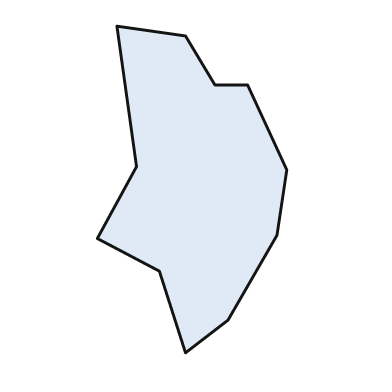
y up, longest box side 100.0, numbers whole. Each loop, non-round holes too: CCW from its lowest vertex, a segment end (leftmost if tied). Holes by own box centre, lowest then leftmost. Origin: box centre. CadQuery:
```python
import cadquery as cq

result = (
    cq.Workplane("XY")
    .moveTo(-2.0, -50.0)
    .lineTo(11.0, -40.0)
    .lineTo(26.0, -14.0)
    .lineTo(29.0, 6.0)
    .lineTo(17.0, 32.0)
    .lineTo(7.0, 32.0)
    .lineTo(-2.0, 47.0)
    .lineTo(-23.0, 50.0)
    .lineTo(-17.0, 7.0)
    .lineTo(-29.0, -15.0)
    .lineTo(-10.0, -25.0)
    .close()
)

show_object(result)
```